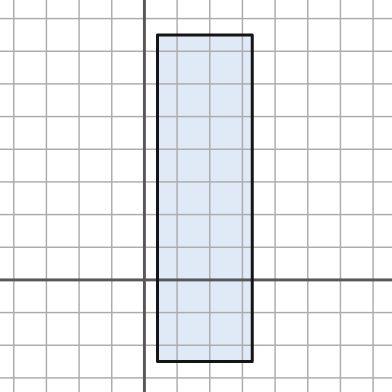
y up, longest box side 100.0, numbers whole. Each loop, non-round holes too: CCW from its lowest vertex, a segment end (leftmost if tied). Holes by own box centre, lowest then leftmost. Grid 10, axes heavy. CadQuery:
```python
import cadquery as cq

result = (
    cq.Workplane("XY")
    .moveTo(4.0, -25.0)
    .lineTo(33.0, -25.0)
    .lineTo(33.0, 75.0)
    .lineTo(4.0, 75.0)
    .close()
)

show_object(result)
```